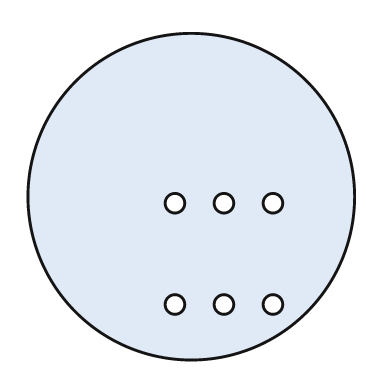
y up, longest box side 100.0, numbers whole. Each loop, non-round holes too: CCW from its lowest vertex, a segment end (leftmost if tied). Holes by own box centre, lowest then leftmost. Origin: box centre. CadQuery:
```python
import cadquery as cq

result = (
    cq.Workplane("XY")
    .moveTo(0.0, 0.0)
    .circle(50.0)
    .moveTo(-5.0, -33.0)
    .circle(3.0)
    .moveTo(10.0, -33.0)
    .circle(3.0)
    .moveTo(25.0, -33.0)
    .circle(3.0)
    .moveTo(-5.0, -2.0)
    .circle(3.0)
    .moveTo(10.0, -2.0)
    .circle(3.0)
    .moveTo(25.0, -2.0)
    .circle(3.0)
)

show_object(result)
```